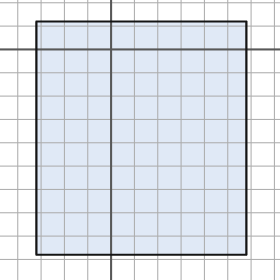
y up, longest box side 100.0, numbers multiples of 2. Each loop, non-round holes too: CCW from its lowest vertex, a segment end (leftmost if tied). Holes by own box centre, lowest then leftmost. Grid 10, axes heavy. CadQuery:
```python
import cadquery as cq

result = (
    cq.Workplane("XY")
    .moveTo(-32.0, -88.0)
    .lineTo(58.0, -88.0)
    .lineTo(58.0, 12.0)
    .lineTo(-32.0, 12.0)
    .close()
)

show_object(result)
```